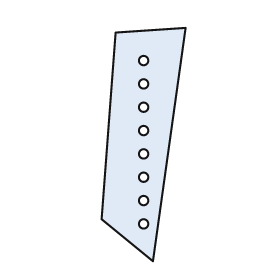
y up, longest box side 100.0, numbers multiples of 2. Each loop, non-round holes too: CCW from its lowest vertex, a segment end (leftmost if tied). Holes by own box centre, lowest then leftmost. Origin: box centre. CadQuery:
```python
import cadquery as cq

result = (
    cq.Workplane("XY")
    .moveTo(4.0, -50.0)
    .lineTo(18.0, 50.0)
    .lineTo(-12.0, 48.0)
    .lineTo(-18.0, -32.0)
    .close()
    .moveTo(0.0, -34.0)
    .circle(2.0)
    .moveTo(0.0, -24.0)
    .circle(2.0)
    .moveTo(0.0, -14.0)
    .circle(2.0)
    .moveTo(0.0, -4.0)
    .circle(2.0)
    .moveTo(0.0, 6.0)
    .circle(2.0)
    .moveTo(0.0, 16.0)
    .circle(2.0)
    .moveTo(0.0, 26.0)
    .circle(2.0)
    .moveTo(0.0, 36.0)
    .circle(2.0)
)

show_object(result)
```